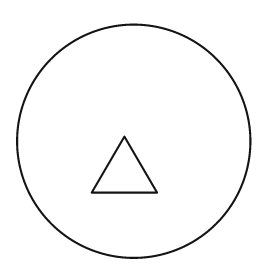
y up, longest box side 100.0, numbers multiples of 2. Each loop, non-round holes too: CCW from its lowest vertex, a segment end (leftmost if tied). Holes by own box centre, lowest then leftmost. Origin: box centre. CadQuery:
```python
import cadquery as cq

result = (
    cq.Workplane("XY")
    .moveTo(0.0, 0.0)
    .circle(50.0)
    .moveTo(-18.0, -22.0)
    .lineTo(10.0, -22.0)
    .lineTo(-4.0, 2.0)
    .close()
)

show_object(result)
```